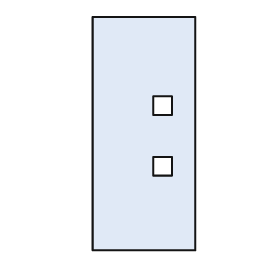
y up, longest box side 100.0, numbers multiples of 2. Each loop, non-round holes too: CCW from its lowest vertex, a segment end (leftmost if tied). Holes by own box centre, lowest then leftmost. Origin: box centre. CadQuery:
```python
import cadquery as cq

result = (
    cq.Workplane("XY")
    .moveTo(-22.0, -50.0)
    .lineTo(22.0, -50.0)
    .lineTo(22.0, 50.0)
    .lineTo(-22.0, 50.0)
    .close()
    .moveTo(4.0, -18.0)
    .lineTo(12.0, -18.0)
    .lineTo(12.0, -10.0)
    .lineTo(4.0, -10.0)
    .close()
    .moveTo(4.0, 8.0)
    .lineTo(12.0, 8.0)
    .lineTo(12.0, 16.0)
    .lineTo(4.0, 16.0)
    .close()
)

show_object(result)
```